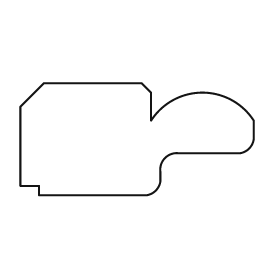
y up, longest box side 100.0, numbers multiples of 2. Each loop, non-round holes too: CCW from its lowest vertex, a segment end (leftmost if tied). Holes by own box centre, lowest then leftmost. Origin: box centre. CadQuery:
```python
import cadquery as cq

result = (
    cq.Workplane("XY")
    .moveTo(-42.0, -24.0)
    .lineTo(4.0, -24.0)
    .threePointArc((8.0, -22.0), (10.0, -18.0))
    .lineTo(10.0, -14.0)
    .threePointArc((12.0, -8.0), (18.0, -6.0))
    .lineTo(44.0, -6.0)
    .threePointArc((48.0, -4.0), (50.0, 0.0))
    .lineTo(50.0, 8.0)
    .threePointArc((28.0, 20.0), (6.0, 8.0))
    .lineTo(6.0, 20.0)
    .lineTo(2.0, 24.0)
    .lineTo(-40.0, 24.0)
    .lineTo(-50.0, 14.0)
    .lineTo(-50.0, -20.0)
    .lineTo(-42.0, -20.0)
    .close()
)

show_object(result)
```